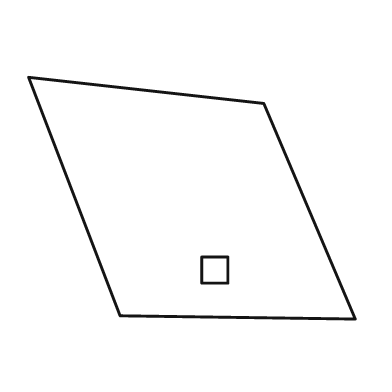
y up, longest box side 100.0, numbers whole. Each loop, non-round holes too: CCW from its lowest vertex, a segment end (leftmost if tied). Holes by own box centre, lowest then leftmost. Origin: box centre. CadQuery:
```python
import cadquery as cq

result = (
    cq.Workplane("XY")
    .moveTo(50.0, -37.0)
    .lineTo(22.0, 29.0)
    .lineTo(-50.0, 37.0)
    .lineTo(-22.0, -36.0)
    .close()
    .moveTo(3.0, -26.0)
    .lineTo(11.0, -26.0)
    .lineTo(11.0, -18.0)
    .lineTo(3.0, -18.0)
    .close()
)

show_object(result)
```